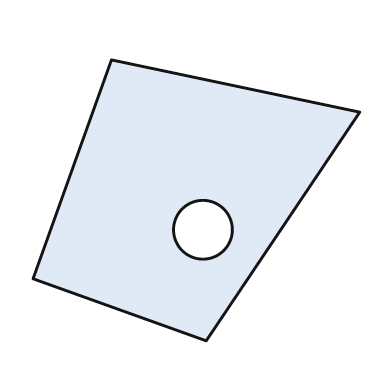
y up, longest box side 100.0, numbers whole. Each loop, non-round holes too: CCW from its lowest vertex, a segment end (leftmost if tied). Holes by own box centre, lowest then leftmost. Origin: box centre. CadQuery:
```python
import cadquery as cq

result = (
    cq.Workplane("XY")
    .moveTo(3.0, -43.0)
    .lineTo(50.0, 27.0)
    .lineTo(-26.0, 43.0)
    .lineTo(-50.0, -24.0)
    .close()
    .moveTo(2.0, -9.0)
    .circle(9.0)
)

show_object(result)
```